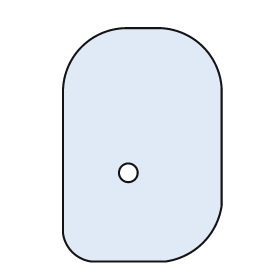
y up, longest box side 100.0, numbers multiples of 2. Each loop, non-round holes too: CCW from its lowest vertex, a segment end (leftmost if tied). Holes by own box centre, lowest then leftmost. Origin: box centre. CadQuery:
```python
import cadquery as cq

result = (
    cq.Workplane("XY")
    .moveTo(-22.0, -50.0)
    .lineTo(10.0, -50.0)
    .threePointArc((26.0, -42.0), (34.0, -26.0))
    .lineTo(34.0, 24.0)
    .threePointArc((26.0, 42.0), (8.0, 50.0))
    .lineTo(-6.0, 50.0)
    .threePointArc((-26.0, 42.0), (-34.0, 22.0))
    .lineTo(-34.0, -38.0)
    .threePointArc((-30.0, -46.0), (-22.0, -50.0))
    .close()
    .moveTo(-6.0, -12.0)
    .circle(4.0)
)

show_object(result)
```